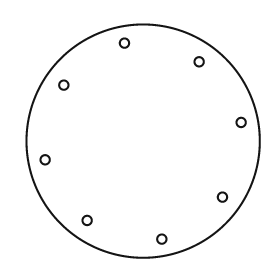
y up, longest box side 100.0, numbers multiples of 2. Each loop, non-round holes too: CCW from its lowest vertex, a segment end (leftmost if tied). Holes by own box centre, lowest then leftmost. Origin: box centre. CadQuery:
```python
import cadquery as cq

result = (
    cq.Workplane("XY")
    .moveTo(0.0, 0.0)
    .circle(50.0)
    .moveTo(8.0, -42.0)
    .circle(2.0)
    .moveTo(-24.0, -34.0)
    .circle(2.0)
    .moveTo(34.0, -24.0)
    .circle(2.0)
    .moveTo(-42.0, -8.0)
    .circle(2.0)
    .moveTo(42.0, 8.0)
    .circle(2.0)
    .moveTo(-34.0, 24.0)
    .circle(2.0)
    .moveTo(24.0, 34.0)
    .circle(2.0)
    .moveTo(-8.0, 42.0)
    .circle(2.0)
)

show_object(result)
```